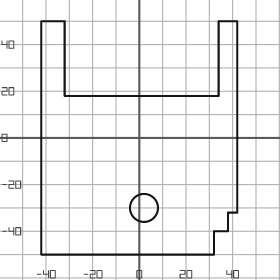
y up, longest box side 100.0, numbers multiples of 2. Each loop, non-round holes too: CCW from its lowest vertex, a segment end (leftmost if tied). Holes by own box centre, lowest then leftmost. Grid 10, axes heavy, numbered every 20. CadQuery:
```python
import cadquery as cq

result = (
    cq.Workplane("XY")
    .moveTo(-42.0, -50.0)
    .lineTo(32.0, -50.0)
    .lineTo(32.0, -40.0)
    .lineTo(38.0, -40.0)
    .lineTo(38.0, -32.0)
    .lineTo(42.0, -32.0)
    .lineTo(42.0, 50.0)
    .lineTo(34.0, 50.0)
    .lineTo(34.0, 18.0)
    .lineTo(-32.0, 18.0)
    .lineTo(-32.0, 50.0)
    .lineTo(-42.0, 50.0)
    .close()
    .moveTo(2.0, -30.0)
    .circle(6.0)
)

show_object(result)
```